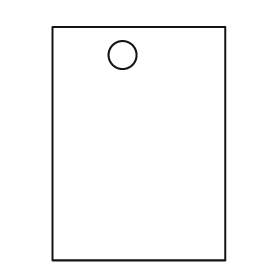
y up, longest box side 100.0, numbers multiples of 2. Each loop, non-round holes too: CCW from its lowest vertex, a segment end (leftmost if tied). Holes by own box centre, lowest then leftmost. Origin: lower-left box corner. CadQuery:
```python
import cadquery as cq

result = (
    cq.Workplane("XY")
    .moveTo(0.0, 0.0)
    .lineTo(74.0, 0.0)
    .lineTo(74.0, 100.0)
    .lineTo(0.0, 100.0)
    .close()
    .moveTo(30.0, 88.0)
    .circle(6.0)
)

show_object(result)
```